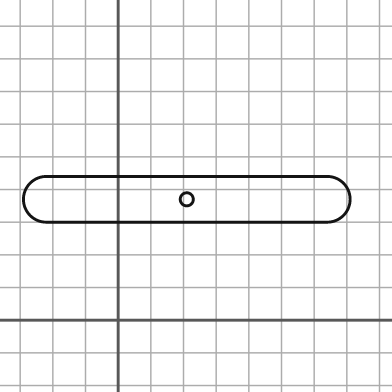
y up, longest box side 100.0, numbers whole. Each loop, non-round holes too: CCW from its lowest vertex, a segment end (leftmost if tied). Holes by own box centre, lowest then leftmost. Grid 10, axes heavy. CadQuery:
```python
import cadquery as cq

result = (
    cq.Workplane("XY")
    .moveTo(-22.0, 30.0)
    .lineTo(64.0, 30.0)
    .threePointArc((71.0, 37.0), (64.0, 44.0))
    .lineTo(-22.0, 44.0)
    .threePointArc((-29.0, 37.0), (-22.0, 30.0))
    .close()
    .moveTo(21.0, 37.0)
    .circle(2.0)
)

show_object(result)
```